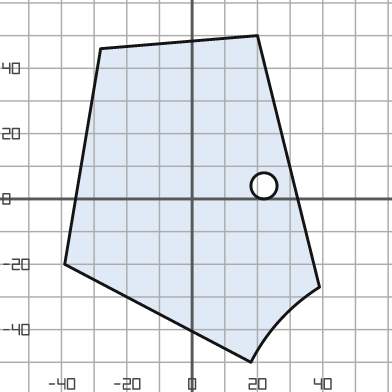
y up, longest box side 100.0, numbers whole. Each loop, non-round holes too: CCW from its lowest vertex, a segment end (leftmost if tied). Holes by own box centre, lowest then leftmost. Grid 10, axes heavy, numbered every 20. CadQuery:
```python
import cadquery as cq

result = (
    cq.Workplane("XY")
    .moveTo(18.0, -50.0)
    .threePointArc((27.0, -37.0), (39.0, -27.0))
    .lineTo(20.0, 50.0)
    .lineTo(-28.0, 46.0)
    .lineTo(-39.0, -20.0)
    .close()
    .moveTo(22.0, 4.0)
    .circle(4.0)
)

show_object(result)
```